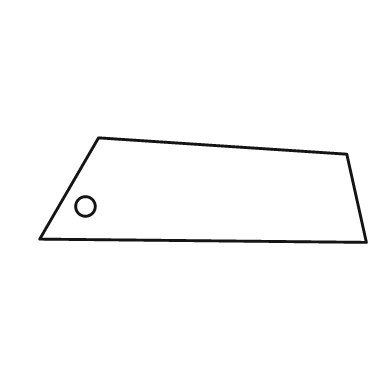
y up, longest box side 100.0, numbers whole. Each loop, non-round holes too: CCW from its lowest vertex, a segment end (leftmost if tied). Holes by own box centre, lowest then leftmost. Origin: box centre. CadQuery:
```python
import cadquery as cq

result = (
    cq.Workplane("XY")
    .moveTo(50.0, -16.0)
    .lineTo(44.0, 11.0)
    .lineTo(-32.0, 16.0)
    .lineTo(-50.0, -15.0)
    .close()
    .moveTo(-36.0, -5.0)
    .circle(3.0)
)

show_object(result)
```